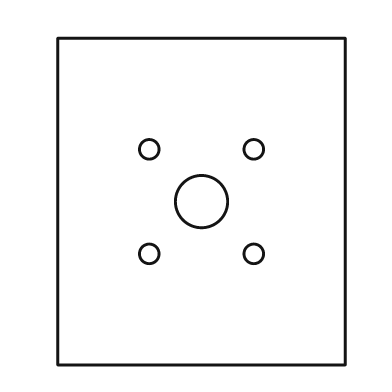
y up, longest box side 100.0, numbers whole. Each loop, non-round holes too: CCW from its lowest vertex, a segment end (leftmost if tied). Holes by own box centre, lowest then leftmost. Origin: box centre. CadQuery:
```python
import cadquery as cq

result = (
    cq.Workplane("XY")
    .moveTo(-44.0, -50.0)
    .lineTo(44.0, -50.0)
    .lineTo(44.0, 50.0)
    .lineTo(-44.0, 50.0)
    .close()
    .moveTo(-16.0, -16.0)
    .circle(3.0)
    .moveTo(16.0, -16.0)
    .circle(3.0)
    .moveTo(0.0, 0.0)
    .circle(8.0)
    .moveTo(-16.0, 16.0)
    .circle(3.0)
    .moveTo(16.0, 16.0)
    .circle(3.0)
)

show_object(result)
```